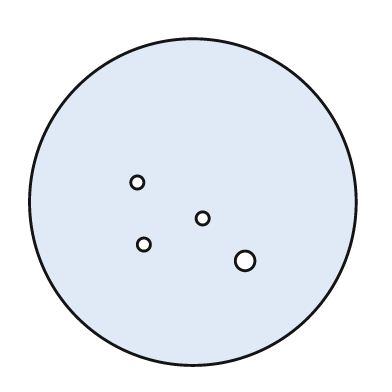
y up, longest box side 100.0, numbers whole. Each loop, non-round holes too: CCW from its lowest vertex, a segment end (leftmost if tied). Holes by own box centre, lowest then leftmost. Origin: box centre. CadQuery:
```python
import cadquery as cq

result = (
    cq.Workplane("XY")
    .moveTo(0.0, 0.0)
    .circle(50.0)
    .moveTo(16.0, -18.0)
    .circle(3.0)
    .moveTo(-15.0, -13.0)
    .circle(2.0)
    .moveTo(3.0, -5.0)
    .circle(2.0)
    .moveTo(-17.0, 6.0)
    .circle(2.0)
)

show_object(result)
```